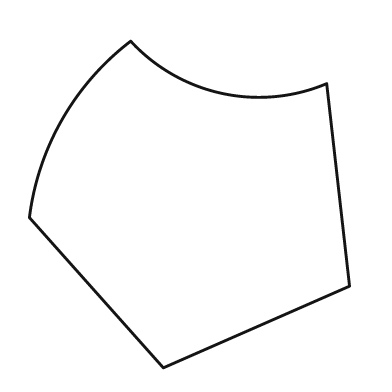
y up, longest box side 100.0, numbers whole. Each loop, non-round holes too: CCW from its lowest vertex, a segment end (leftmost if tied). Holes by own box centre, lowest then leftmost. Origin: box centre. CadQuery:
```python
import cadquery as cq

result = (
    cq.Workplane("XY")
    .moveTo(-8.0, -50.0)
    .lineTo(49.0, -25.0)
    .lineTo(42.0, 37.0)
    .threePointArc((10.0, 34.0), (-18.0, 50.0))
    .threePointArc((-39.0, 26.0), (-49.0, -4.0))
    .close()
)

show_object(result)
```